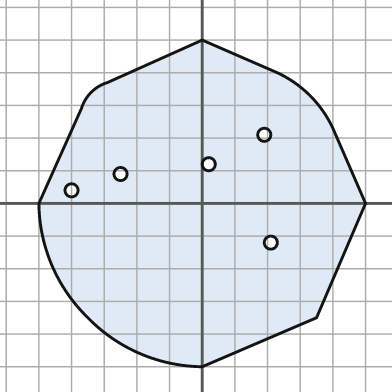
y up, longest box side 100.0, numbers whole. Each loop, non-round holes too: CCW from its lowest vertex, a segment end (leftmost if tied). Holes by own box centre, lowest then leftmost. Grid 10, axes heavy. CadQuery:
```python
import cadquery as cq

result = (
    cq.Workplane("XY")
    .moveTo(0.0, -50.0)
    .lineTo(35.0, -35.0)
    .lineTo(50.0, 0.0)
    .lineTo(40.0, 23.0)
    .threePointArc((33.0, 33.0), (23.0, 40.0))
    .lineTo(0.0, 50.0)
    .lineTo(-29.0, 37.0)
    .threePointArc((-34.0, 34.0), (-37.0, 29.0))
    .lineTo(-50.0, 0.0)
    .threePointArc((-46.0, -19.0), (-35.0, -35.0))
    .threePointArc((-19.0, -46.0), (0.0, -50.0))
    .close()
    .moveTo(21.0, -12.0)
    .circle(2.0)
    .moveTo(-40.0, 4.0)
    .circle(2.0)
    .moveTo(-25.0, 9.0)
    .circle(2.0)
    .moveTo(2.0, 12.0)
    .circle(2.0)
    .moveTo(19.0, 21.0)
    .circle(2.0)
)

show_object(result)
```